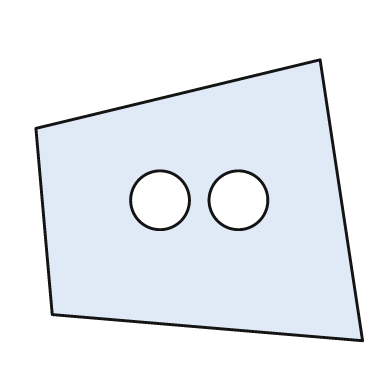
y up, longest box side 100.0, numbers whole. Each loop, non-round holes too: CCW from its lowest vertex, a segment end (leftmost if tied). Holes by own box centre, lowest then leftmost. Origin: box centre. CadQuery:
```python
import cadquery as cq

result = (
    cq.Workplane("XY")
    .moveTo(50.0, -43.0)
    .lineTo(37.0, 43.0)
    .lineTo(-50.0, 22.0)
    .lineTo(-45.0, -35.0)
    .close()
    .moveTo(-12.0, 0.0)
    .circle(9.0)
    .moveTo(12.0, 0.0)
    .circle(9.0)
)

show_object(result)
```